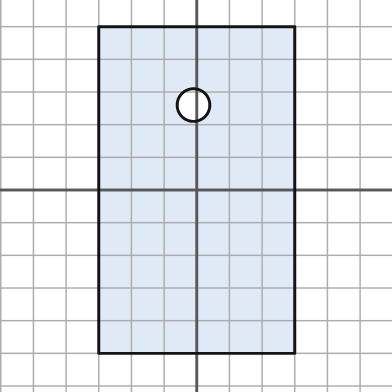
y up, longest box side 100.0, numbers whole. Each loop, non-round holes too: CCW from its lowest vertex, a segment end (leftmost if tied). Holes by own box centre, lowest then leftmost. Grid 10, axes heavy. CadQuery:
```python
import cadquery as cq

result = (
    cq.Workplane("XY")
    .moveTo(-30.0, -50.0)
    .lineTo(30.0, -50.0)
    .lineTo(30.0, 50.0)
    .lineTo(-30.0, 50.0)
    .close()
    .moveTo(-1.0, 26.0)
    .circle(5.0)
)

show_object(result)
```